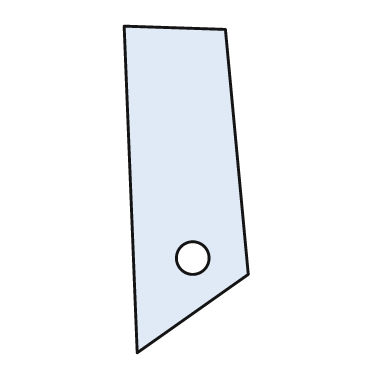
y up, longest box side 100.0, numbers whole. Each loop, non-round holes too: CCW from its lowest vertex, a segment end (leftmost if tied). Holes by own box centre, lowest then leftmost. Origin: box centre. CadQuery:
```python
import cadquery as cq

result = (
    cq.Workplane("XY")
    .moveTo(-15.0, -50.0)
    .lineTo(19.0, -26.0)
    .lineTo(12.0, 49.0)
    .lineTo(-19.0, 50.0)
    .close()
    .moveTo(2.0, -21.0)
    .circle(5.0)
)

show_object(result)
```